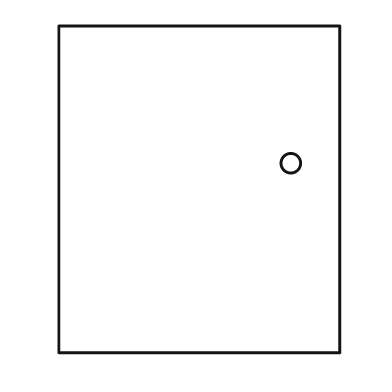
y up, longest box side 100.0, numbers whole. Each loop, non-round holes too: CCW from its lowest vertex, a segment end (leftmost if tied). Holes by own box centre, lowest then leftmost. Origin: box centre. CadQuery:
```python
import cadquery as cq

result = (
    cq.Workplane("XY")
    .moveTo(-43.0, -50.0)
    .lineTo(43.0, -50.0)
    .lineTo(43.0, 50.0)
    .lineTo(-43.0, 50.0)
    .close()
    .moveTo(28.0, 8.0)
    .circle(3.0)
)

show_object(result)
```